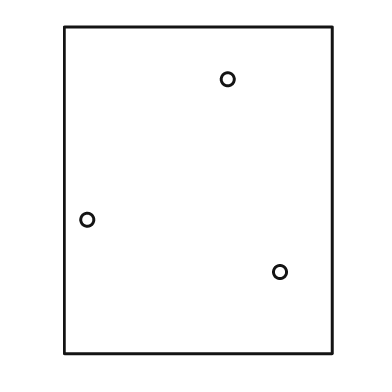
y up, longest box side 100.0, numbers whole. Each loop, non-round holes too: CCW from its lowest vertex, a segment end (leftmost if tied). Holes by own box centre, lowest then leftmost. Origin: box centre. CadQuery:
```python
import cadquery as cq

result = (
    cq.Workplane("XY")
    .moveTo(-41.0, -50.0)
    .lineTo(41.0, -50.0)
    .lineTo(41.0, 50.0)
    .lineTo(-41.0, 50.0)
    .close()
    .moveTo(25.0, -25.0)
    .circle(2.0)
    .moveTo(-34.0, -9.0)
    .circle(2.0)
    .moveTo(9.0, 34.0)
    .circle(2.0)
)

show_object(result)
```